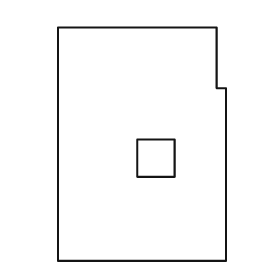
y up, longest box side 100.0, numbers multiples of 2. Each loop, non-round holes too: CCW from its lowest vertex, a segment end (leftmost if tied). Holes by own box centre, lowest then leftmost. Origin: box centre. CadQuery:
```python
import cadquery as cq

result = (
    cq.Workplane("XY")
    .moveTo(-36.0, -50.0)
    .lineTo(36.0, -50.0)
    .lineTo(36.0, 24.0)
    .lineTo(32.0, 24.0)
    .lineTo(32.0, 50.0)
    .lineTo(-36.0, 50.0)
    .close()
    .moveTo(-2.0, -14.0)
    .lineTo(14.0, -14.0)
    .lineTo(14.0, 2.0)
    .lineTo(-2.0, 2.0)
    .close()
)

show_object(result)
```